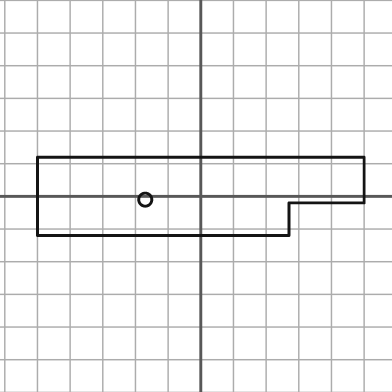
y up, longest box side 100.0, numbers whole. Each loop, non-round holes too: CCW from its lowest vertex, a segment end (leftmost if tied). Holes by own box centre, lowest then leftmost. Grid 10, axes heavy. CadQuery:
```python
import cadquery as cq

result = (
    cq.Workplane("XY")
    .moveTo(-50.0, -12.0)
    .lineTo(27.0, -12.0)
    .lineTo(27.0, -2.0)
    .lineTo(50.0, -2.0)
    .lineTo(50.0, 12.0)
    .lineTo(-50.0, 12.0)
    .close()
    .moveTo(-17.0, -1.0)
    .circle(2.0)
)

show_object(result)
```